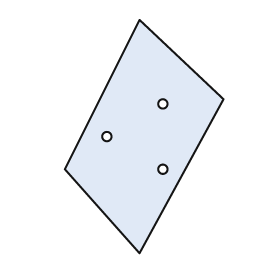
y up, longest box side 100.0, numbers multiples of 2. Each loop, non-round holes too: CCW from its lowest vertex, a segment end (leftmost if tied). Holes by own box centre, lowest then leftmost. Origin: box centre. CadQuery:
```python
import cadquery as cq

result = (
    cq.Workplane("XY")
    .moveTo(-2.0, -50.0)
    .lineTo(34.0, 16.0)
    .lineTo(-2.0, 50.0)
    .lineTo(-34.0, -14.0)
    .close()
    .moveTo(8.0, -14.0)
    .circle(2.0)
    .moveTo(-16.0, 0.0)
    .circle(2.0)
    .moveTo(8.0, 14.0)
    .circle(2.0)
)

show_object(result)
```